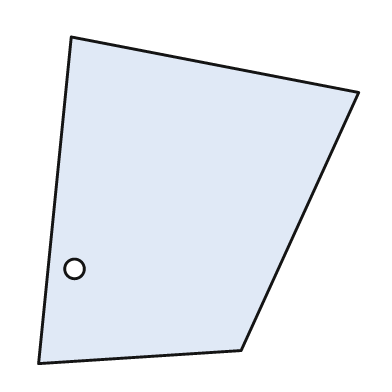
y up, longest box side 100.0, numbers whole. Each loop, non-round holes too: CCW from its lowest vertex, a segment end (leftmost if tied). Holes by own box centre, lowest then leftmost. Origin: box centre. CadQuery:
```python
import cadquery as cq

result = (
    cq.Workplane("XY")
    .moveTo(-49.0, -50.0)
    .lineTo(13.0, -46.0)
    .lineTo(49.0, 33.0)
    .lineTo(-39.0, 50.0)
    .close()
    .moveTo(-38.0, -21.0)
    .circle(3.0)
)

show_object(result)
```